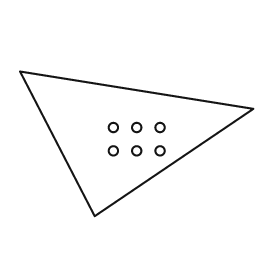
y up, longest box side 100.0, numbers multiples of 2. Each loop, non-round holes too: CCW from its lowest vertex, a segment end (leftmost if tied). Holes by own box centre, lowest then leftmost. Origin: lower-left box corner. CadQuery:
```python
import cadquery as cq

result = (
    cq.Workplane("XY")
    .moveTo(32.0, 0.0)
    .lineTo(100.0, 46.0)
    .lineTo(0.0, 62.0)
    .close()
    .moveTo(40.0, 28.0)
    .circle(2.0)
    .moveTo(50.0, 28.0)
    .circle(2.0)
    .moveTo(60.0, 28.0)
    .circle(2.0)
    .moveTo(40.0, 38.0)
    .circle(2.0)
    .moveTo(50.0, 38.0)
    .circle(2.0)
    .moveTo(60.0, 38.0)
    .circle(2.0)
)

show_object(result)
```